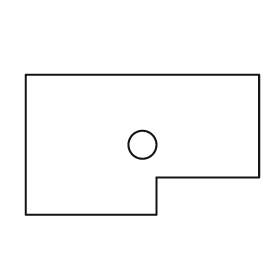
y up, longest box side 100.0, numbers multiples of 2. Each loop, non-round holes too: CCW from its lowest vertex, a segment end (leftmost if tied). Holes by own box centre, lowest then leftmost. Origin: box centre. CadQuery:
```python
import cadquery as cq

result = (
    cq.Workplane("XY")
    .moveTo(-50.0, -30.0)
    .lineTo(6.0, -30.0)
    .lineTo(6.0, -14.0)
    .lineTo(50.0, -14.0)
    .lineTo(50.0, 30.0)
    .lineTo(-50.0, 30.0)
    .close()
    .moveTo(0.0, 0.0)
    .circle(6.0)
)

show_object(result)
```